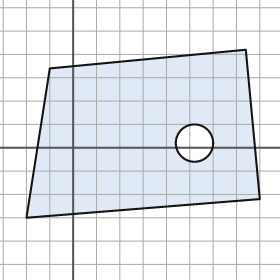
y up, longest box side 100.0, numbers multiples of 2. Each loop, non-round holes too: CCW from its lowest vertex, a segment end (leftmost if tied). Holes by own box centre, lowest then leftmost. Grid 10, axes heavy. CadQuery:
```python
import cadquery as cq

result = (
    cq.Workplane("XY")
    .moveTo(-20.0, -30.0)
    .lineTo(80.0, -22.0)
    .lineTo(74.0, 42.0)
    .lineTo(-10.0, 34.0)
    .close()
    .moveTo(52.0, 2.0)
    .circle(8.0)
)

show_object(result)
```